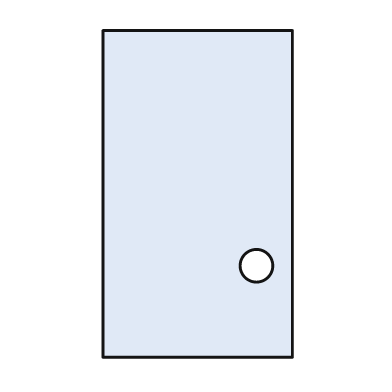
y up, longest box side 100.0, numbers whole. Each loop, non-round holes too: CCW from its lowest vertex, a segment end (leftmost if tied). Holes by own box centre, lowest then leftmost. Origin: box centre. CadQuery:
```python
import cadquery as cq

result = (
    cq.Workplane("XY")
    .moveTo(-29.0, -50.0)
    .lineTo(29.0, -50.0)
    .lineTo(29.0, 50.0)
    .lineTo(-29.0, 50.0)
    .close()
    .moveTo(18.0, -22.0)
    .circle(5.0)
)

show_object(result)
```